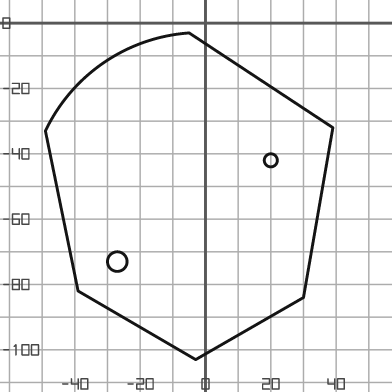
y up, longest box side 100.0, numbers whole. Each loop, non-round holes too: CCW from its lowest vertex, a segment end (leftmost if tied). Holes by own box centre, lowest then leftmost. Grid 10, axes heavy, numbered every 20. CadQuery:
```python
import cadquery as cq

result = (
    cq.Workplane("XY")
    .moveTo(-3.0, -103.0)
    .lineTo(30.0, -84.0)
    .lineTo(39.0, -32.0)
    .lineTo(-5.0, -3.0)
    .threePointArc((-31.0, -12.0), (-49.0, -33.0))
    .lineTo(-39.0, -82.0)
    .close()
    .moveTo(-27.0, -73.0)
    .circle(3.0)
    .moveTo(20.0, -42.0)
    .circle(2.0)
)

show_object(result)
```